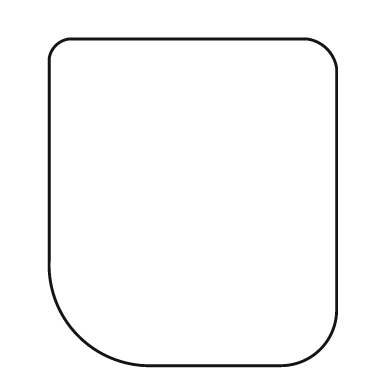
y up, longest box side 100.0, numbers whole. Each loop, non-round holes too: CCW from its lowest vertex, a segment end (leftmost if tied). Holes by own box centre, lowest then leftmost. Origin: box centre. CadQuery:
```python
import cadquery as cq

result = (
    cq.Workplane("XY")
    .moveTo(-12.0, -50.0)
    .lineTo(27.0, -50.0)
    .threePointArc((39.0, -45.0), (44.0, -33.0))
    .lineTo(44.0, 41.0)
    .threePointArc((41.0, 47.0), (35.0, 50.0))
    .lineTo(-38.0, 50.0)
    .threePointArc((-42.0, 48.0), (-44.0, 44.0))
    .lineTo(-44.0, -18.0)
    .threePointArc((-35.0, -41.0), (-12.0, -50.0))
    .close()
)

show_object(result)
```